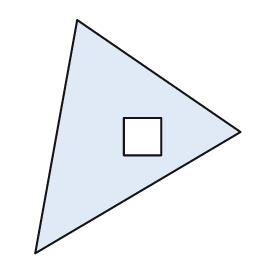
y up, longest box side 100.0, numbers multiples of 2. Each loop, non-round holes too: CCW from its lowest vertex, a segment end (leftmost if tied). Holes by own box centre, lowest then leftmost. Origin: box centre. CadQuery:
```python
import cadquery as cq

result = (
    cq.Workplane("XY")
    .moveTo(-44.0, -50.0)
    .lineTo(44.0, 2.0)
    .lineTo(-26.0, 50.0)
    .close()
    .moveTo(-6.0, -8.0)
    .lineTo(10.0, -8.0)
    .lineTo(10.0, 8.0)
    .lineTo(-6.0, 8.0)
    .close()
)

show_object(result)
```